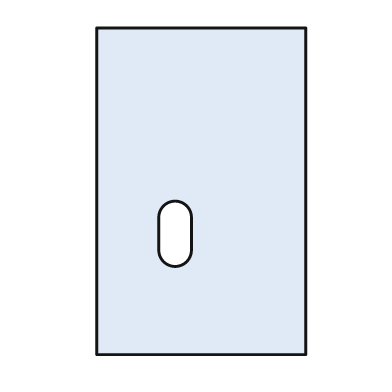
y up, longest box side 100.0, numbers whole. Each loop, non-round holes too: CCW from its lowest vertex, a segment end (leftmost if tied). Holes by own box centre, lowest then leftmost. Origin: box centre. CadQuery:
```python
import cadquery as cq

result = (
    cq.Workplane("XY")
    .moveTo(-32.0, -50.0)
    .lineTo(32.0, -50.0)
    .lineTo(32.0, 50.0)
    .lineTo(-32.0, 50.0)
    .close()
    .moveTo(-13.0, -18.0)
    .threePointArc((-8.0, -23.0), (-3.0, -18.0))
    .lineTo(-3.0, -8.0)
    .threePointArc((-8.0, -3.0), (-13.0, -8.0))
    .close()
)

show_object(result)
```